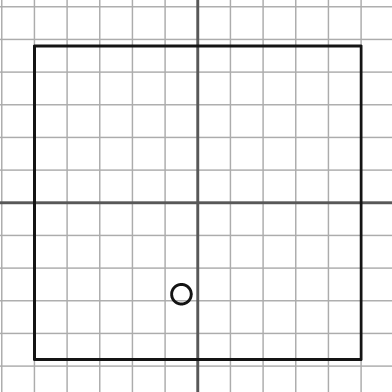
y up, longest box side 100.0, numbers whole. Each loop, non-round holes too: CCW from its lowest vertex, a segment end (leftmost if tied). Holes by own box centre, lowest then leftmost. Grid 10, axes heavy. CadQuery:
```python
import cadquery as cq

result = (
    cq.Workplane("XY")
    .moveTo(-50.0, -48.0)
    .lineTo(50.0, -48.0)
    .lineTo(50.0, 48.0)
    .lineTo(-50.0, 48.0)
    .close()
    .moveTo(-5.0, -28.0)
    .circle(3.0)
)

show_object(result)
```